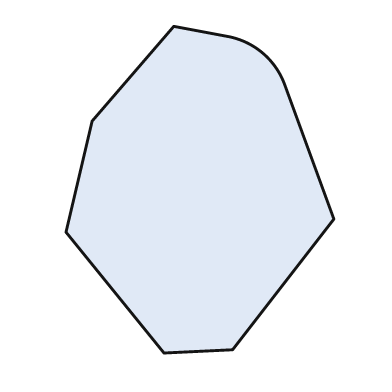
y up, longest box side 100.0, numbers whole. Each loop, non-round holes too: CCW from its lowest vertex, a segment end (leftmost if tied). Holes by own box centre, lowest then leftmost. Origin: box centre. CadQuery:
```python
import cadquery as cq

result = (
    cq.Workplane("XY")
    .moveTo(-11.0, -50.0)
    .lineTo(10.0, -49.0)
    .lineTo(41.0, -9.0)
    .lineTo(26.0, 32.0)
    .threePointArc((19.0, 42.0), (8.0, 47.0))
    .lineTo(-8.0, 50.0)
    .lineTo(-33.0, 21.0)
    .lineTo(-41.0, -13.0)
    .close()
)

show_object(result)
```